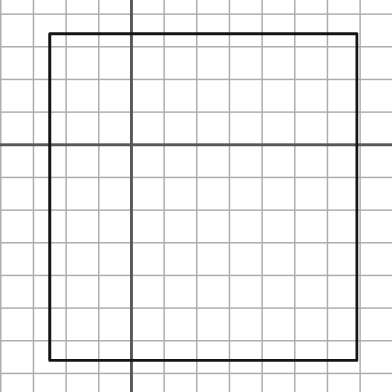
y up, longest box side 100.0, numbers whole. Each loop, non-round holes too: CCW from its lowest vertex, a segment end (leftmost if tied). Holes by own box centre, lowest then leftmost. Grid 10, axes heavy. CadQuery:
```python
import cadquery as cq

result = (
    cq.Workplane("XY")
    .moveTo(-25.0, -66.0)
    .lineTo(69.0, -66.0)
    .lineTo(69.0, 34.0)
    .lineTo(-25.0, 34.0)
    .close()
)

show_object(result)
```